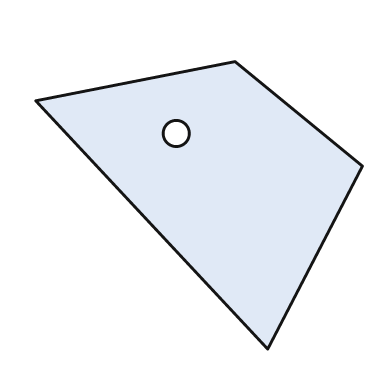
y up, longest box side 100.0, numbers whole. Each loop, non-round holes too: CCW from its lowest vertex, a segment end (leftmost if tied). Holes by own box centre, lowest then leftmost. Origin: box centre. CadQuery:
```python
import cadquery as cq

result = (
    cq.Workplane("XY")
    .moveTo(21.0, -44.0)
    .lineTo(50.0, 12.0)
    .lineTo(11.0, 44.0)
    .lineTo(-50.0, 32.0)
    .close()
    .moveTo(-7.0, 22.0)
    .circle(4.0)
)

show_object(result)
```